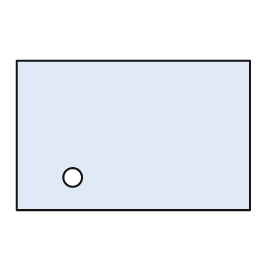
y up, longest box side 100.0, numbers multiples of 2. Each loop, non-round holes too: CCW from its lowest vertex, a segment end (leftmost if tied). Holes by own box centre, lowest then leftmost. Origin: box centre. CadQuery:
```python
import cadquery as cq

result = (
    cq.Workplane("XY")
    .moveTo(-50.0, -32.0)
    .lineTo(50.0, -32.0)
    .lineTo(50.0, 32.0)
    .lineTo(-50.0, 32.0)
    .close()
    .moveTo(-26.0, -18.0)
    .circle(4.0)
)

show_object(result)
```